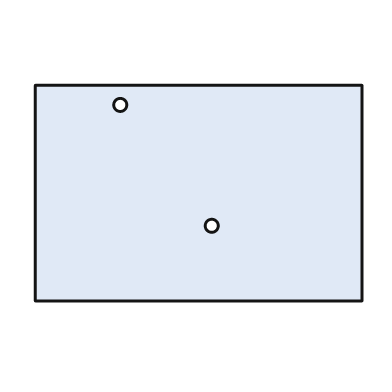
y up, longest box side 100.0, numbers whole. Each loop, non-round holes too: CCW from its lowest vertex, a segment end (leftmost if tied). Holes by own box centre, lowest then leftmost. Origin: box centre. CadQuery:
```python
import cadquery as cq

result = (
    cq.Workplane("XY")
    .moveTo(-50.0, -33.0)
    .lineTo(50.0, -33.0)
    .lineTo(50.0, 33.0)
    .lineTo(-50.0, 33.0)
    .close()
    .moveTo(4.0, -10.0)
    .circle(2.0)
    .moveTo(-24.0, 27.0)
    .circle(2.0)
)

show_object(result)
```